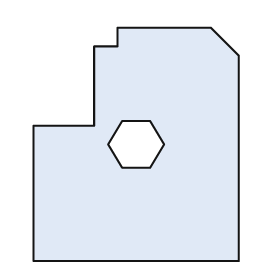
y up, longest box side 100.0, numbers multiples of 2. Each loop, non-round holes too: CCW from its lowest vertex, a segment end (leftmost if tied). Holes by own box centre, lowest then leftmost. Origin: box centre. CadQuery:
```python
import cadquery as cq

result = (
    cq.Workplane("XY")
    .moveTo(-44.0, -50.0)
    .lineTo(44.0, -50.0)
    .lineTo(44.0, 38.0)
    .lineTo(32.0, 50.0)
    .lineTo(-8.0, 50.0)
    .lineTo(-8.0, 42.0)
    .lineTo(-18.0, 42.0)
    .lineTo(-18.0, 8.0)
    .lineTo(-44.0, 8.0)
    .close()
    .moveTo(-6.0, -10.0)
    .lineTo(6.0, -10.0)
    .lineTo(12.0, 0.0)
    .lineTo(6.0, 10.0)
    .lineTo(-6.0, 10.0)
    .lineTo(-12.0, 0.0)
    .close()
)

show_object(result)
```